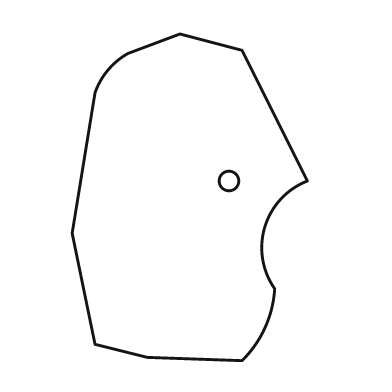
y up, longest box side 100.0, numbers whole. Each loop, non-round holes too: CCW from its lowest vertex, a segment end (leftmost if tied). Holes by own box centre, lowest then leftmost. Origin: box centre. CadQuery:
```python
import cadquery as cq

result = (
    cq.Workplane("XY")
    .moveTo(16.0, -50.0)
    .threePointArc((23.0, -40.0), (26.0, -28.0))
    .threePointArc((23.0, -9.0), (36.0, 5.0))
    .lineTo(16.0, 45.0)
    .lineTo(-3.0, 50.0)
    .lineTo(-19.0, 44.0)
    .threePointArc((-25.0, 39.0), (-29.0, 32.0))
    .lineTo(-36.0, -11.0)
    .lineTo(-29.0, -45.0)
    .lineTo(-13.0, -49.0)
    .close()
    .moveTo(12.0, 5.0)
    .circle(3.0)
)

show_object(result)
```